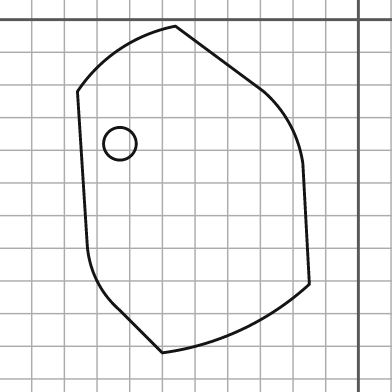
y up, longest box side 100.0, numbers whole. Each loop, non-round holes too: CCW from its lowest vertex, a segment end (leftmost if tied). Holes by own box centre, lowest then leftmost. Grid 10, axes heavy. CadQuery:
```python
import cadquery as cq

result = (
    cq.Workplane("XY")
    .moveTo(-60.0, -102.0)
    .threePointArc((-36.0, -95.0), (-15.0, -81.0))
    .lineTo(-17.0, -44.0)
    .threePointArc((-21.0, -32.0), (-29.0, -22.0))
    .lineTo(-56.0, -2.0)
    .threePointArc((-73.0, -9.0), (-86.0, -22.0))
    .lineTo(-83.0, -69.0)
    .threePointArc((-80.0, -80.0), (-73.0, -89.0))
    .close()
    .moveTo(-73.0, -38.0)
    .circle(5.0)
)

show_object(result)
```